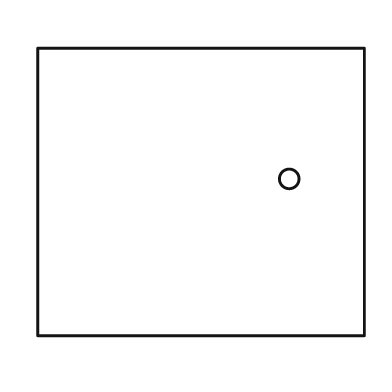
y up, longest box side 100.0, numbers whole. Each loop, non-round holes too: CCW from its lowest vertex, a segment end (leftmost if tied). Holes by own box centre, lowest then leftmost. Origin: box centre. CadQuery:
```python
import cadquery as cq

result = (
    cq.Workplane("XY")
    .moveTo(-50.0, -44.0)
    .lineTo(50.0, -44.0)
    .lineTo(50.0, 44.0)
    .lineTo(-50.0, 44.0)
    .close()
    .moveTo(27.0, 4.0)
    .circle(3.0)
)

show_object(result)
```